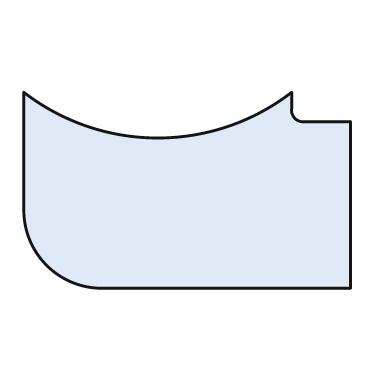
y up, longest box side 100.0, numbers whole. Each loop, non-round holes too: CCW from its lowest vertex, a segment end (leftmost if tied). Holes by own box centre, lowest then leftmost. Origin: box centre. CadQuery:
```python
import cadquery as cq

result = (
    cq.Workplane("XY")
    .moveTo(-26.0, -30.0)
    .lineTo(50.0, -30.0)
    .lineTo(50.0, 21.0)
    .lineTo(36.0, 21.0)
    .threePointArc((33.0, 22.0), (32.0, 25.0))
    .lineTo(32.0, 30.0)
    .threePointArc((-9.0, 16.0), (-50.0, 30.0))
    .lineTo(-50.0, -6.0)
    .threePointArc((-43.0, -23.0), (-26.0, -30.0))
    .close()
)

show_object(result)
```